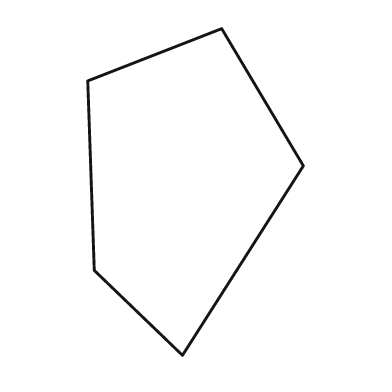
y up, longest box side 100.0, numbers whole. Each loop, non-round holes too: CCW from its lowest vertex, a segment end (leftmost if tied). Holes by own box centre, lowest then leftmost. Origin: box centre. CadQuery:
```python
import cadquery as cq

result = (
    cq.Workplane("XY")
    .moveTo(-4.0, -50.0)
    .lineTo(33.0, 8.0)
    .lineTo(8.0, 50.0)
    .lineTo(-33.0, 34.0)
    .lineTo(-31.0, -24.0)
    .close()
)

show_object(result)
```